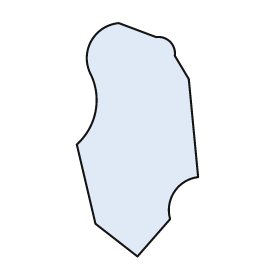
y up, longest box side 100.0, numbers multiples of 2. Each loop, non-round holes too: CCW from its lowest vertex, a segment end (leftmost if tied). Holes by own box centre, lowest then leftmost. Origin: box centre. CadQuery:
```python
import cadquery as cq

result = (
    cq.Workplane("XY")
    .moveTo(0.0, -50.0)
    .lineTo(14.0, -34.0)
    .threePointArc((16.0, -22.0), (26.0, -16.0))
    .lineTo(22.0, 26.0)
    .lineTo(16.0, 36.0)
    .threePointArc((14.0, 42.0), (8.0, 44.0))
    .lineTo(-8.0, 50.0)
    .threePointArc((-20.0, 42.0), (-20.0, 28.0))
    .threePointArc((-18.0, 12.0), (-26.0, -2.0))
    .lineTo(-18.0, -36.0)
    .close()
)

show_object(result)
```